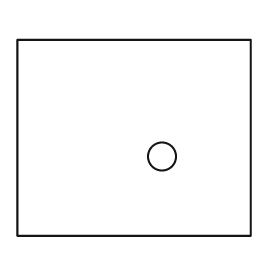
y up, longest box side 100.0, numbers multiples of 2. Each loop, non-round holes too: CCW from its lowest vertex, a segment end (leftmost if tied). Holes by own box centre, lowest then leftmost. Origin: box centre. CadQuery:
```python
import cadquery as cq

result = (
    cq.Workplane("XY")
    .moveTo(-50.0, -42.0)
    .lineTo(50.0, -42.0)
    .lineTo(50.0, 42.0)
    .lineTo(-50.0, 42.0)
    .close()
    .moveTo(12.0, -8.0)
    .circle(6.0)
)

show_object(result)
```